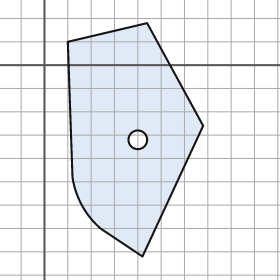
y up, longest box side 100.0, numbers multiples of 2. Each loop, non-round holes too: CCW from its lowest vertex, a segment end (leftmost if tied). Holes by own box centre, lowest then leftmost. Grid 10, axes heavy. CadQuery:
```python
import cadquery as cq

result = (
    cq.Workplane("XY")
    .moveTo(42.0, -82.0)
    .lineTo(68.0, -26.0)
    .lineTo(44.0, 18.0)
    .lineTo(10.0, 10.0)
    .lineTo(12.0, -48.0)
    .threePointArc((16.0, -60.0), (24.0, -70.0))
    .close()
    .moveTo(40.0, -32.0)
    .circle(4.0)
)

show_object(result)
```